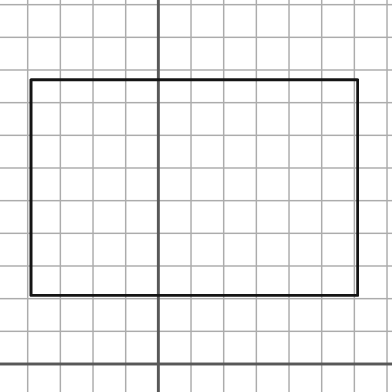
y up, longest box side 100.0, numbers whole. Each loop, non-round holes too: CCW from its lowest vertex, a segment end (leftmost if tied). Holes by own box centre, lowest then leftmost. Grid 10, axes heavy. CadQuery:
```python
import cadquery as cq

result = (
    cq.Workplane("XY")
    .moveTo(-39.0, 21.0)
    .lineTo(61.0, 21.0)
    .lineTo(61.0, 87.0)
    .lineTo(-39.0, 87.0)
    .close()
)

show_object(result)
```